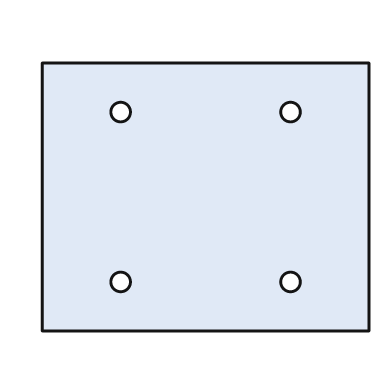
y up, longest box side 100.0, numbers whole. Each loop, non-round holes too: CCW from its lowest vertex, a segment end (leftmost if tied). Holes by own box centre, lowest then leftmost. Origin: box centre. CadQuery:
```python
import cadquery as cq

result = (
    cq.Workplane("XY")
    .moveTo(-50.0, -41.0)
    .lineTo(50.0, -41.0)
    .lineTo(50.0, 41.0)
    .lineTo(-50.0, 41.0)
    .close()
    .moveTo(-26.0, -26.0)
    .circle(3.0)
    .moveTo(26.0, -26.0)
    .circle(3.0)
    .moveTo(-26.0, 26.0)
    .circle(3.0)
    .moveTo(26.0, 26.0)
    .circle(3.0)
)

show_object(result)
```